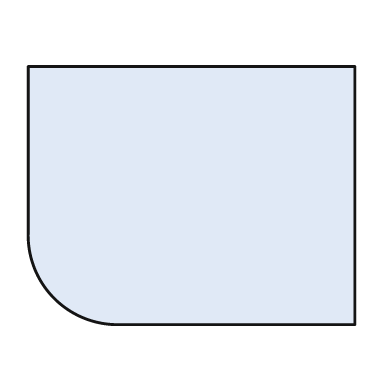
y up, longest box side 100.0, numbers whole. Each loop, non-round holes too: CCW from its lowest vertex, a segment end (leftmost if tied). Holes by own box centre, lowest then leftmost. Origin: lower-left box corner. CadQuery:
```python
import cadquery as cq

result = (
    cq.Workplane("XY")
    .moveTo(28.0, 0.0)
    .lineTo(100.0, 0.0)
    .lineTo(100.0, 79.0)
    .lineTo(0.0, 79.0)
    .lineTo(0.0, 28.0)
    .threePointArc((8.0, 8.0), (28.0, 0.0))
    .close()
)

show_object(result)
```